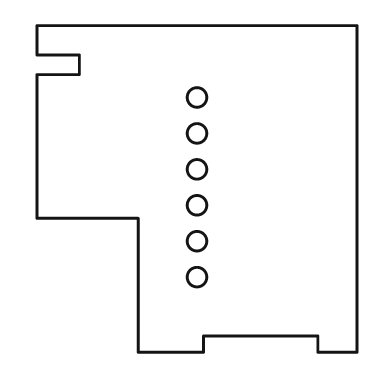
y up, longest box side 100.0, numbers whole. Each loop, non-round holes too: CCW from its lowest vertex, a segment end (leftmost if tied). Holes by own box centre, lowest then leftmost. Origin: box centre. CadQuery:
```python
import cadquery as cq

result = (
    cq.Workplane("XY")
    .moveTo(-18.0, -50.0)
    .lineTo(2.0, -50.0)
    .lineTo(2.0, -45.0)
    .lineTo(37.0, -45.0)
    .lineTo(37.0, -50.0)
    .lineTo(49.0, -50.0)
    .lineTo(49.0, 50.0)
    .lineTo(-49.0, 50.0)
    .lineTo(-49.0, 41.0)
    .lineTo(-36.0, 41.0)
    .lineTo(-36.0, 35.0)
    .lineTo(-49.0, 35.0)
    .lineTo(-49.0, -9.0)
    .lineTo(-18.0, -9.0)
    .close()
    .moveTo(0.0, -27.0)
    .circle(3.0)
    .moveTo(0.0, -16.0)
    .circle(3.0)
    .moveTo(0.0, -5.0)
    .circle(3.0)
    .moveTo(0.0, 6.0)
    .circle(3.0)
    .moveTo(0.0, 17.0)
    .circle(3.0)
    .moveTo(0.0, 28.0)
    .circle(3.0)
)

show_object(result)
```